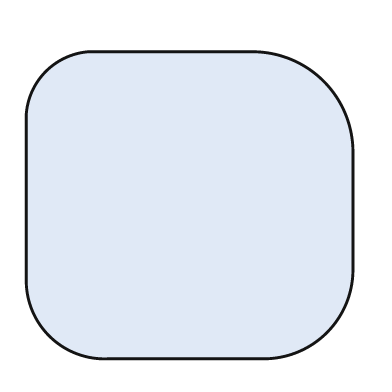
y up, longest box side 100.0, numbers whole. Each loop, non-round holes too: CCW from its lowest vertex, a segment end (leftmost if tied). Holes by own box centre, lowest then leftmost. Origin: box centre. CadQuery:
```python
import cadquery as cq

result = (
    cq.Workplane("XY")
    .moveTo(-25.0, -47.0)
    .lineTo(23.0, -47.0)
    .threePointArc((42.0, -39.0), (50.0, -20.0))
    .lineTo(50.0, 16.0)
    .threePointArc((41.0, 38.0), (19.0, 47.0))
    .lineTo(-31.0, 47.0)
    .threePointArc((-44.0, 41.0), (-50.0, 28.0))
    .lineTo(-50.0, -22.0)
    .threePointArc((-43.0, -40.0), (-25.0, -47.0))
    .close()
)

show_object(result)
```